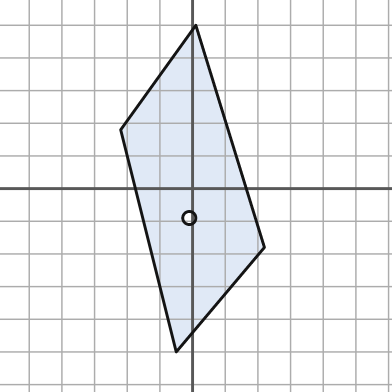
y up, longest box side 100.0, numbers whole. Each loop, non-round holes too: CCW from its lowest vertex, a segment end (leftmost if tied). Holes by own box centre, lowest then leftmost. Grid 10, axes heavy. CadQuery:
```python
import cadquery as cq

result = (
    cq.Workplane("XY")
    .moveTo(-5.0, -50.0)
    .lineTo(22.0, -18.0)
    .lineTo(1.0, 50.0)
    .lineTo(-22.0, 18.0)
    .close()
    .moveTo(-1.0, -9.0)
    .circle(2.0)
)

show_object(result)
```